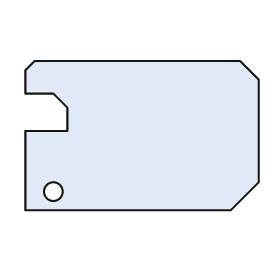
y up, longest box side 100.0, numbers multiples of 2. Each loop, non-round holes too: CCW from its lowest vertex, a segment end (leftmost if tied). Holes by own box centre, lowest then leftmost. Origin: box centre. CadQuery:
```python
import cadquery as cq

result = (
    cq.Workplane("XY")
    .moveTo(-50.0, -32.0)
    .lineTo(38.0, -32.0)
    .lineTo(50.0, -20.0)
    .lineTo(50.0, 24.0)
    .lineTo(42.0, 32.0)
    .lineTo(-46.0, 32.0)
    .lineTo(-50.0, 28.0)
    .lineTo(-50.0, 18.0)
    .lineTo(-38.0, 18.0)
    .lineTo(-32.0, 12.0)
    .lineTo(-32.0, 2.0)
    .lineTo(-50.0, 2.0)
    .close()
    .moveTo(-38.0, -24.0)
    .circle(4.0)
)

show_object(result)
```